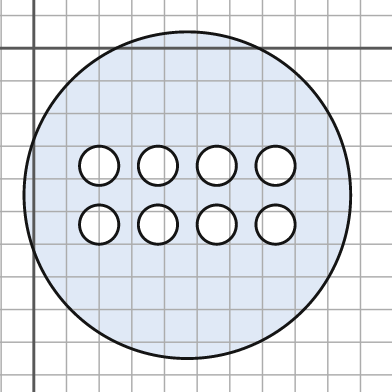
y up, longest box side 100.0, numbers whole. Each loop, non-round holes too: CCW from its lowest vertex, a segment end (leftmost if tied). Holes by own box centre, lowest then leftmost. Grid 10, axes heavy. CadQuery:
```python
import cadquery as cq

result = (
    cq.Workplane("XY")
    .moveTo(47.0, -45.0)
    .circle(50.0)
    .moveTo(20.0, -54.0)
    .circle(6.0)
    .moveTo(38.0, -54.0)
    .circle(6.0)
    .moveTo(56.0, -54.0)
    .circle(6.0)
    .moveTo(74.0, -54.0)
    .circle(6.0)
    .moveTo(20.0, -36.0)
    .circle(6.0)
    .moveTo(38.0, -36.0)
    .circle(6.0)
    .moveTo(56.0, -36.0)
    .circle(6.0)
    .moveTo(74.0, -36.0)
    .circle(6.0)
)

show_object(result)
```